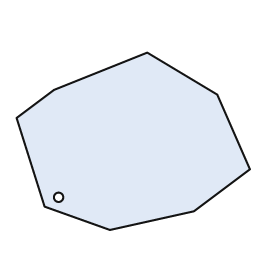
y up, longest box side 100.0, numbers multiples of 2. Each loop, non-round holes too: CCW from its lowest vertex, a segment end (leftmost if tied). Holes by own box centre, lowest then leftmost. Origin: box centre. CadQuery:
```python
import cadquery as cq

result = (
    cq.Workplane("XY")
    .moveTo(-10.0, -38.0)
    .lineTo(26.0, -30.0)
    .lineTo(50.0, -12.0)
    .lineTo(36.0, 20.0)
    .lineTo(6.0, 38.0)
    .lineTo(-34.0, 22.0)
    .lineTo(-50.0, 10.0)
    .lineTo(-38.0, -28.0)
    .close()
    .moveTo(-32.0, -24.0)
    .circle(2.0)
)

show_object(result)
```